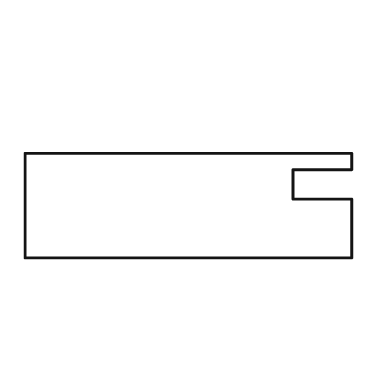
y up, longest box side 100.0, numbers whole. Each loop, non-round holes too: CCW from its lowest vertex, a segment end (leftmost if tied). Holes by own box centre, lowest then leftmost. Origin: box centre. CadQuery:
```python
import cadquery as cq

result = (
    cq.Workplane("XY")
    .moveTo(-50.0, -16.0)
    .lineTo(50.0, -16.0)
    .lineTo(50.0, 2.0)
    .lineTo(32.0, 2.0)
    .lineTo(32.0, 11.0)
    .lineTo(50.0, 11.0)
    .lineTo(50.0, 16.0)
    .lineTo(-50.0, 16.0)
    .close()
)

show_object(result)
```